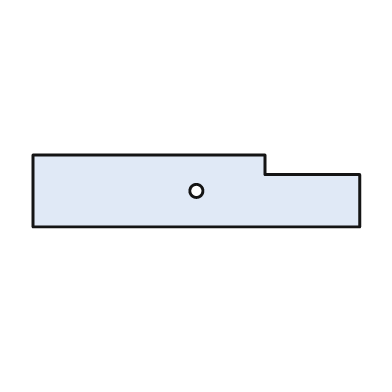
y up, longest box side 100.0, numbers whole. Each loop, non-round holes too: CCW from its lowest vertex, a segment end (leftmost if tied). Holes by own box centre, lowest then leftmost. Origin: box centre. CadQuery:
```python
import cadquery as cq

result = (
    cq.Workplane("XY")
    .moveTo(-50.0, -11.0)
    .lineTo(50.0, -11.0)
    .lineTo(50.0, 5.0)
    .lineTo(21.0, 5.0)
    .lineTo(21.0, 11.0)
    .lineTo(-50.0, 11.0)
    .close()
    .moveTo(0.0, 0.0)
    .circle(2.0)
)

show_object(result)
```